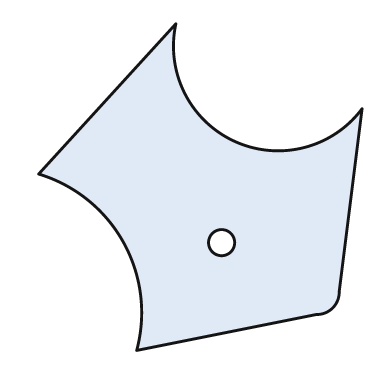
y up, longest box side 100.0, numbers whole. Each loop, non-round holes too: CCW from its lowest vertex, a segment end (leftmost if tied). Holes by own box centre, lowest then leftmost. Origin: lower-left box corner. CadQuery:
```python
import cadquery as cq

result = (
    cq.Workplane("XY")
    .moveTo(30.0, 0.0)
    .lineTo(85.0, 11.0)
    .threePointArc((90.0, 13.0), (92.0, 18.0))
    .lineTo(99.0, 74.0)
    .threePointArc((60.0, 64.0), (42.0, 100.0))
    .lineTo(0.0, 54.0)
    .threePointArc((26.0, 33.0), (30.0, 0.0))
    .close()
    .moveTo(56.0, 33.0)
    .circle(4.0)
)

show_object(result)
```